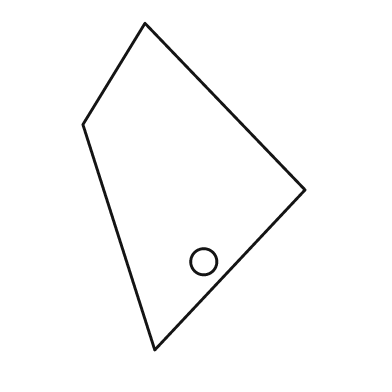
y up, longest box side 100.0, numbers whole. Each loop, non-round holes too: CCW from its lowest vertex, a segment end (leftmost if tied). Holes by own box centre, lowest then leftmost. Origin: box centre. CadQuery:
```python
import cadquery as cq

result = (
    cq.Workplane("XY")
    .moveTo(-12.0, -50.0)
    .lineTo(34.0, -1.0)
    .lineTo(-15.0, 50.0)
    .lineTo(-34.0, 19.0)
    .close()
    .moveTo(3.0, -23.0)
    .circle(4.0)
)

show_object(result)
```